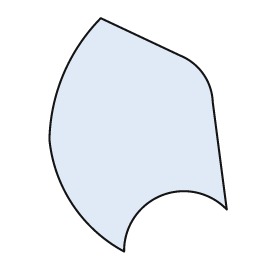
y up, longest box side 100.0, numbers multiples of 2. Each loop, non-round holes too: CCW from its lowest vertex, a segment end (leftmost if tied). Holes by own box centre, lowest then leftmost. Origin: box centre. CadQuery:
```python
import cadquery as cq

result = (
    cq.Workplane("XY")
    .moveTo(-6.0, -50.0)
    .threePointArc((10.0, -26.0), (38.0, -32.0))
    .lineTo(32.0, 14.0)
    .threePointArc((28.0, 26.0), (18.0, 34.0))
    .lineTo(-16.0, 50.0)
    .threePointArc((-32.0, 26.0), (-38.0, -2.0))
    .threePointArc((-28.0, -30.0), (-6.0, -50.0))
    .close()
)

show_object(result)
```